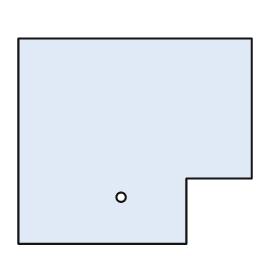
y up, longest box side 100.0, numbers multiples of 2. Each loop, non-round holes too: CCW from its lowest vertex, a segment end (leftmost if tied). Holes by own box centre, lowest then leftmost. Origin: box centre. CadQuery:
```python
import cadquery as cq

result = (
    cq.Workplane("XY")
    .moveTo(-50.0, -44.0)
    .lineTo(22.0, -44.0)
    .lineTo(22.0, -16.0)
    .lineTo(50.0, -16.0)
    .lineTo(50.0, 44.0)
    .lineTo(-50.0, 44.0)
    .close()
    .moveTo(-6.0, -24.0)
    .circle(2.0)
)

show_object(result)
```